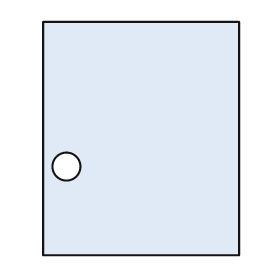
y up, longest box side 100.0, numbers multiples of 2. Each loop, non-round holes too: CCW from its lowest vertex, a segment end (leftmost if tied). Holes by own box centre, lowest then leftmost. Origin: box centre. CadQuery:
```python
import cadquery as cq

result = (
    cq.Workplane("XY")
    .moveTo(-42.0, -50.0)
    .lineTo(42.0, -50.0)
    .lineTo(42.0, 50.0)
    .lineTo(-42.0, 50.0)
    .close()
    .moveTo(-32.0, -12.0)
    .circle(6.0)
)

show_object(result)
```